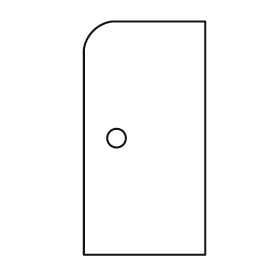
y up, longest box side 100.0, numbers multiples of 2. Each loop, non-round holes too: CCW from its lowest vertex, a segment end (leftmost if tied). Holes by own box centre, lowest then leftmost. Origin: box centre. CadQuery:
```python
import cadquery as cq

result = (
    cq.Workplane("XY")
    .moveTo(-26.0, -50.0)
    .lineTo(26.0, -50.0)
    .lineTo(26.0, 50.0)
    .lineTo(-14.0, 50.0)
    .threePointArc((-22.0, 46.0), (-26.0, 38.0))
    .close()
    .moveTo(-12.0, 0.0)
    .circle(4.0)
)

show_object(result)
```